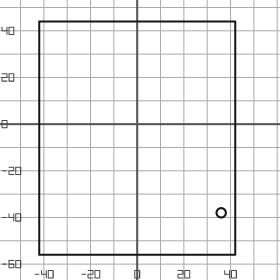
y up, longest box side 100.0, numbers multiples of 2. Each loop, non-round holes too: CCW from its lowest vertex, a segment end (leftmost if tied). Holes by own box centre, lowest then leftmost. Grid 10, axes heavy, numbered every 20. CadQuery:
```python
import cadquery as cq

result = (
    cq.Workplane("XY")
    .moveTo(-42.0, -56.0)
    .lineTo(42.0, -56.0)
    .lineTo(42.0, 44.0)
    .lineTo(-42.0, 44.0)
    .close()
    .moveTo(36.0, -38.0)
    .circle(2.0)
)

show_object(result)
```